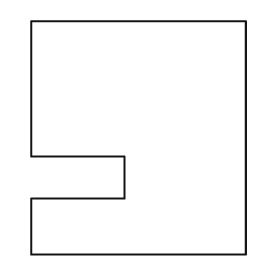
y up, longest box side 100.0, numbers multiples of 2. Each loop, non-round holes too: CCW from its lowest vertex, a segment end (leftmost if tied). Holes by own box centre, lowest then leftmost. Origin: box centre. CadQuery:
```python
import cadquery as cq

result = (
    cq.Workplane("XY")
    .moveTo(-46.0, -50.0)
    .lineTo(46.0, -50.0)
    .lineTo(46.0, 50.0)
    .lineTo(-46.0, 50.0)
    .lineTo(-46.0, -8.0)
    .lineTo(-6.0, -8.0)
    .lineTo(-6.0, -26.0)
    .lineTo(-46.0, -26.0)
    .close()
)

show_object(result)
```